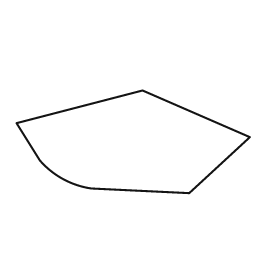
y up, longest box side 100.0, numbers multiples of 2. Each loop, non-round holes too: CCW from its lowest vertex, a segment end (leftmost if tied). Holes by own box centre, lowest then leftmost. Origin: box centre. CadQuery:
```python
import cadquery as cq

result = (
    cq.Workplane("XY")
    .moveTo(24.0, -22.0)
    .lineTo(50.0, 2.0)
    .lineTo(4.0, 22.0)
    .lineTo(-50.0, 8.0)
    .lineTo(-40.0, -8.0)
    .threePointArc((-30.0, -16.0), (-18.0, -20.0))
    .close()
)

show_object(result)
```